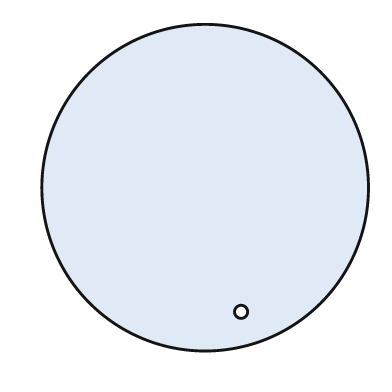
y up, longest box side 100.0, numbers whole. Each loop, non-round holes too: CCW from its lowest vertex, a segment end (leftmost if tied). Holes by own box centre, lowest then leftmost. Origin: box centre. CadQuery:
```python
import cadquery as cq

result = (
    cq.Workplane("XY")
    .moveTo(0.0, 0.0)
    .circle(50.0)
    .moveTo(11.0, -38.0)
    .circle(2.0)
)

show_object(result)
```